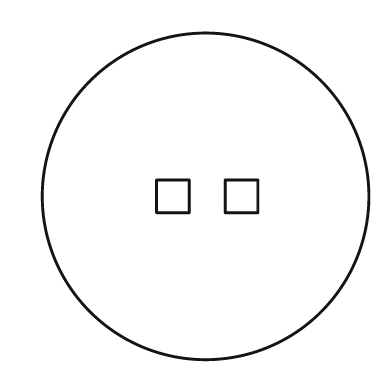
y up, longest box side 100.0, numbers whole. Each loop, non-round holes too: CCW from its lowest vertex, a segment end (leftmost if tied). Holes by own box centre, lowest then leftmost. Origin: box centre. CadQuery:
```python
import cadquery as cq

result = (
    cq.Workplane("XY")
    .moveTo(0.0, 0.0)
    .circle(50.0)
    .moveTo(-15.0, -5.0)
    .lineTo(-5.0, -5.0)
    .lineTo(-5.0, 5.0)
    .lineTo(-15.0, 5.0)
    .close()
    .moveTo(6.0, -5.0)
    .lineTo(16.0, -5.0)
    .lineTo(16.0, 5.0)
    .lineTo(6.0, 5.0)
    .close()
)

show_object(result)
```